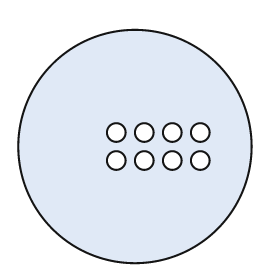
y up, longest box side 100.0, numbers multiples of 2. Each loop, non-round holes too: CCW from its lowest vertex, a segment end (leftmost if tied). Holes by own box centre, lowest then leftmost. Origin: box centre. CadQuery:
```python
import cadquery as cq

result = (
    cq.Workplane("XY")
    .moveTo(0.0, 0.0)
    .circle(50.0)
    .moveTo(-8.0, -6.0)
    .circle(4.0)
    .moveTo(4.0, -6.0)
    .circle(4.0)
    .moveTo(16.0, -6.0)
    .circle(4.0)
    .moveTo(28.0, -6.0)
    .circle(4.0)
    .moveTo(-8.0, 6.0)
    .circle(4.0)
    .moveTo(4.0, 6.0)
    .circle(4.0)
    .moveTo(16.0, 6.0)
    .circle(4.0)
    .moveTo(28.0, 6.0)
    .circle(4.0)
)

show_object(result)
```